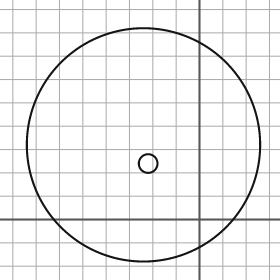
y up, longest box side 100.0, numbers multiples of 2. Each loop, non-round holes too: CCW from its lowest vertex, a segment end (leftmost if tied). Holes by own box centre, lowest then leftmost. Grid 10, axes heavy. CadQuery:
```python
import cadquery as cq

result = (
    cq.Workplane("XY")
    .moveTo(-24.0, 32.0)
    .circle(50.0)
    .moveTo(-22.0, 24.0)
    .circle(4.0)
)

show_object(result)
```